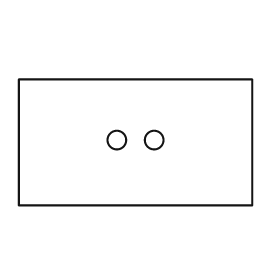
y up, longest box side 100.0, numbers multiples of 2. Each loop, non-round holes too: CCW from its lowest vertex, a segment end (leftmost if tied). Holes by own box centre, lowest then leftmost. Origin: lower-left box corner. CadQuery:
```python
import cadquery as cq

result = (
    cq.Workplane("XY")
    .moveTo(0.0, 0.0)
    .lineTo(100.0, 0.0)
    .lineTo(100.0, 54.0)
    .lineTo(0.0, 54.0)
    .close()
    .moveTo(42.0, 28.0)
    .circle(4.0)
    .moveTo(58.0, 28.0)
    .circle(4.0)
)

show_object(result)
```